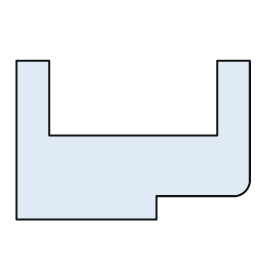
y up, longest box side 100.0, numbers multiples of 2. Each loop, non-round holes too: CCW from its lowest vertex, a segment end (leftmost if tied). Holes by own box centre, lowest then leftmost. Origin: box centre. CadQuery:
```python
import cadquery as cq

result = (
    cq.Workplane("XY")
    .moveTo(-50.0, -34.0)
    .lineTo(10.0, -34.0)
    .lineTo(10.0, -24.0)
    .lineTo(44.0, -24.0)
    .threePointArc((48.0, -22.0), (50.0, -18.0))
    .lineTo(50.0, 34.0)
    .lineTo(36.0, 34.0)
    .lineTo(36.0, 2.0)
    .lineTo(-36.0, 2.0)
    .lineTo(-36.0, 34.0)
    .lineTo(-50.0, 34.0)
    .close()
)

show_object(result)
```